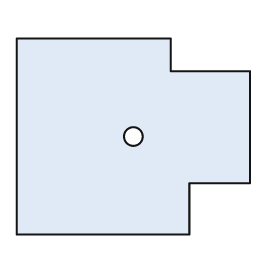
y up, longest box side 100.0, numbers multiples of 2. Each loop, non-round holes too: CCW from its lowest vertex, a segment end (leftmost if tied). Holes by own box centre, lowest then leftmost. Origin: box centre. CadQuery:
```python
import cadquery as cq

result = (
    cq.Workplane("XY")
    .moveTo(-50.0, -42.0)
    .lineTo(24.0, -42.0)
    .lineTo(24.0, -20.0)
    .lineTo(50.0, -20.0)
    .lineTo(50.0, 28.0)
    .lineTo(16.0, 28.0)
    .lineTo(16.0, 42.0)
    .lineTo(-50.0, 42.0)
    .close()
    .moveTo(0.0, 0.0)
    .circle(4.0)
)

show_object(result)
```